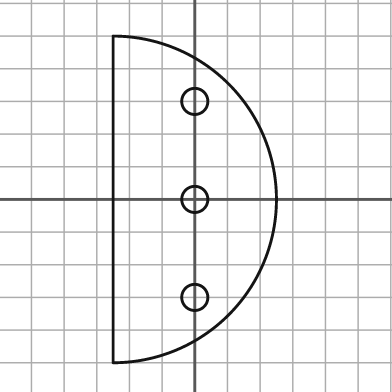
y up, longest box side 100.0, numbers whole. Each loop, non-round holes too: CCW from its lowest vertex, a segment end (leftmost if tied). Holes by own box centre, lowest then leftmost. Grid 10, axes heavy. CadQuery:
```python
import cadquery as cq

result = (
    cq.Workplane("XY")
    .moveTo(-25.0, -50.0)
    .threePointArc((25.0, 0.0), (-25.0, 50.0))
    .close()
    .moveTo(0.0, -30.0)
    .circle(4.0)
    .moveTo(0.0, 0.0)
    .circle(4.0)
    .moveTo(0.0, 30.0)
    .circle(4.0)
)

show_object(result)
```